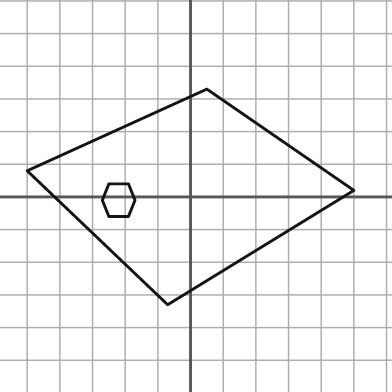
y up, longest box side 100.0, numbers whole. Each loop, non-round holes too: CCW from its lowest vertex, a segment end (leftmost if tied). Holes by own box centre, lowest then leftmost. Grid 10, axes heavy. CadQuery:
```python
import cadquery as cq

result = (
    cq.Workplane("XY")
    .moveTo(-7.0, -33.0)
    .lineTo(50.0, 2.0)
    .lineTo(5.0, 33.0)
    .lineTo(-50.0, 8.0)
    .close()
    .moveTo(-25.0, -6.0)
    .lineTo(-19.0, -6.0)
    .lineTo(-17.0, -1.0)
    .lineTo(-19.0, 4.0)
    .lineTo(-25.0, 4.0)
    .lineTo(-27.0, -1.0)
    .close()
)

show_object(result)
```